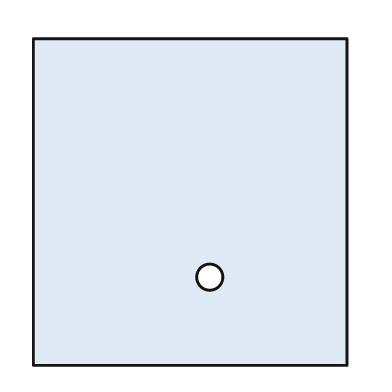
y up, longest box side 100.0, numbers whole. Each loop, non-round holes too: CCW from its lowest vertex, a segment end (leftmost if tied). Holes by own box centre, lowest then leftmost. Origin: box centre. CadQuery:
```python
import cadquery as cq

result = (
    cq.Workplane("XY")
    .moveTo(-48.0, -50.0)
    .lineTo(48.0, -50.0)
    .lineTo(48.0, 50.0)
    .lineTo(-48.0, 50.0)
    .close()
    .moveTo(6.0, -23.0)
    .circle(4.0)
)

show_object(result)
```